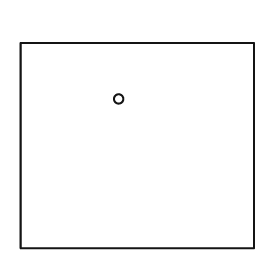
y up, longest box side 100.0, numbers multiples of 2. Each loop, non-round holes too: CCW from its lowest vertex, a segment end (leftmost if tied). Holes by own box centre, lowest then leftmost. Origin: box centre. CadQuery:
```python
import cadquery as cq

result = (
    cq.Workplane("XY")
    .moveTo(-50.0, -44.0)
    .lineTo(50.0, -44.0)
    .lineTo(50.0, 44.0)
    .lineTo(-50.0, 44.0)
    .close()
    .moveTo(-8.0, 20.0)
    .circle(2.0)
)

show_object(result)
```